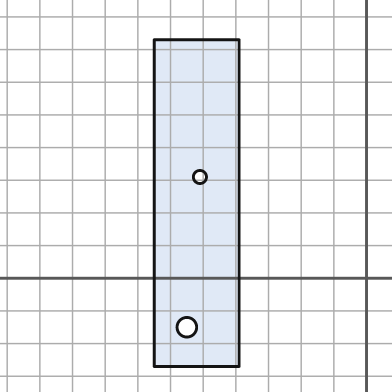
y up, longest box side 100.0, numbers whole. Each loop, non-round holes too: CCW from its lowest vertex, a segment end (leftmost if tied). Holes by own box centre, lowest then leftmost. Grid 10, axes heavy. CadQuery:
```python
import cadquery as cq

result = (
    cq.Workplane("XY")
    .moveTo(-65.0, -27.0)
    .lineTo(-39.0, -27.0)
    .lineTo(-39.0, 73.0)
    .lineTo(-65.0, 73.0)
    .close()
    .moveTo(-55.0, -15.0)
    .circle(3.0)
    .moveTo(-51.0, 31.0)
    .circle(2.0)
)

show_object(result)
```